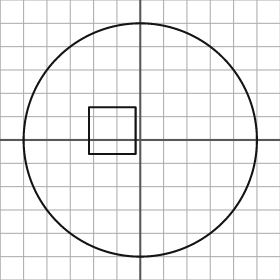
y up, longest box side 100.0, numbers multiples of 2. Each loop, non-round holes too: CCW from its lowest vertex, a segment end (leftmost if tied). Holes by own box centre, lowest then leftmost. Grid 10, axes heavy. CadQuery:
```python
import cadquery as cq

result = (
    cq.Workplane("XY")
    .moveTo(0.0, 0.0)
    .circle(50.0)
    .moveTo(-22.0, -6.0)
    .lineTo(-2.0, -6.0)
    .lineTo(-2.0, 14.0)
    .lineTo(-22.0, 14.0)
    .close()
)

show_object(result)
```